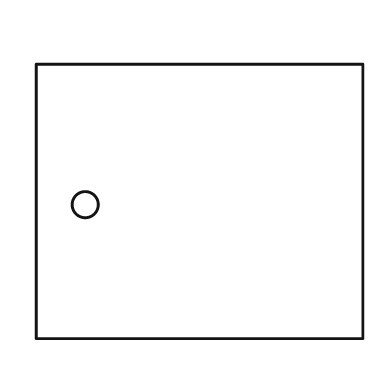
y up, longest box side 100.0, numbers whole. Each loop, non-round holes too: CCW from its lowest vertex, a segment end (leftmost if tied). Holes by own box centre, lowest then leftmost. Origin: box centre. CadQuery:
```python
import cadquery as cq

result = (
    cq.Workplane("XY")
    .moveTo(-50.0, -42.0)
    .lineTo(50.0, -42.0)
    .lineTo(50.0, 42.0)
    .lineTo(-50.0, 42.0)
    .close()
    .moveTo(-35.0, -1.0)
    .circle(4.0)
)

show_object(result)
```